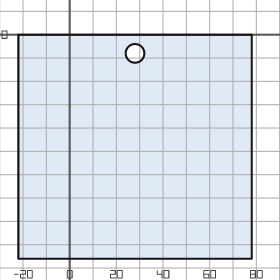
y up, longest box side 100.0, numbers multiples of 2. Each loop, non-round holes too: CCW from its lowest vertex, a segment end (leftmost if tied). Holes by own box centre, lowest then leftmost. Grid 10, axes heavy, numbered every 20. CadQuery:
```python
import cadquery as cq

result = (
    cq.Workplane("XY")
    .moveTo(-22.0, -96.0)
    .lineTo(78.0, -96.0)
    .lineTo(78.0, 0.0)
    .lineTo(-22.0, 0.0)
    .close()
    .moveTo(28.0, -8.0)
    .circle(4.0)
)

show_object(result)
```